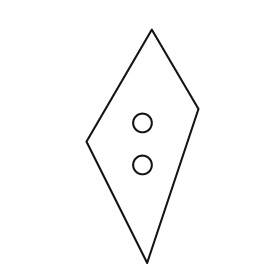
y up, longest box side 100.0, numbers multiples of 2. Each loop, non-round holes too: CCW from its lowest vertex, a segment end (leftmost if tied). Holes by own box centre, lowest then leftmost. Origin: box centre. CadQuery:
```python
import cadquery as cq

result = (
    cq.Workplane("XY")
    .moveTo(2.0, -50.0)
    .lineTo(24.0, 16.0)
    .lineTo(4.0, 50.0)
    .lineTo(-24.0, 2.0)
    .close()
    .moveTo(0.0, -8.0)
    .circle(4.0)
    .moveTo(0.0, 10.0)
    .circle(4.0)
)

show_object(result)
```